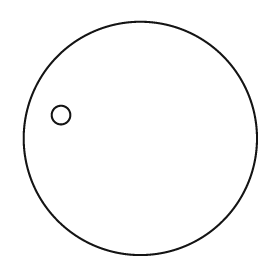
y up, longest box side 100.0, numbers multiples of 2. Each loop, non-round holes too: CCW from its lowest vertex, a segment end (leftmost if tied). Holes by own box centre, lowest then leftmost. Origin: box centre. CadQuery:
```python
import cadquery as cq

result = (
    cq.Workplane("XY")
    .moveTo(0.0, 0.0)
    .circle(50.0)
    .moveTo(-34.0, 10.0)
    .circle(4.0)
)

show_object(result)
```